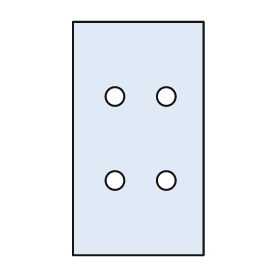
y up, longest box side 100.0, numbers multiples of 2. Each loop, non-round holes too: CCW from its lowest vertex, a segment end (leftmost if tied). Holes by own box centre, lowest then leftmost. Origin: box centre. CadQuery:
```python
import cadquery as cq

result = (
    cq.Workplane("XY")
    .moveTo(-28.0, -50.0)
    .lineTo(28.0, -50.0)
    .lineTo(28.0, 50.0)
    .lineTo(-28.0, 50.0)
    .close()
    .moveTo(-10.0, -18.0)
    .circle(4.0)
    .moveTo(12.0, -18.0)
    .circle(4.0)
    .moveTo(-10.0, 18.0)
    .circle(4.0)
    .moveTo(12.0, 18.0)
    .circle(4.0)
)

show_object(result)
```